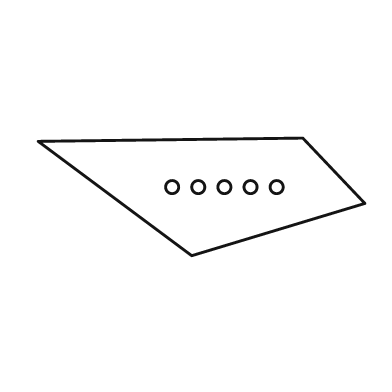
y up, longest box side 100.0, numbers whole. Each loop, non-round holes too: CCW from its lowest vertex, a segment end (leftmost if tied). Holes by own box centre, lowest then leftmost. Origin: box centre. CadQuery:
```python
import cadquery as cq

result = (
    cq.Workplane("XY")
    .moveTo(-3.0, -18.0)
    .lineTo(50.0, -2.0)
    .lineTo(31.0, 18.0)
    .lineTo(-50.0, 17.0)
    .close()
    .moveTo(-9.0, 3.0)
    .circle(2.0)
    .moveTo(-1.0, 3.0)
    .circle(2.0)
    .moveTo(7.0, 3.0)
    .circle(2.0)
    .moveTo(15.0, 3.0)
    .circle(2.0)
    .moveTo(23.0, 3.0)
    .circle(2.0)
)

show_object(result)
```